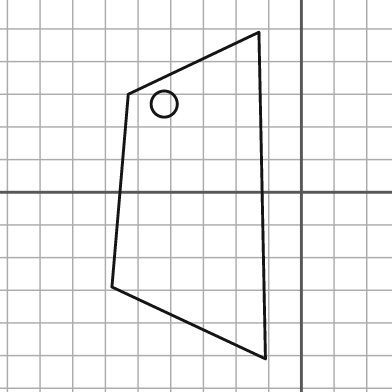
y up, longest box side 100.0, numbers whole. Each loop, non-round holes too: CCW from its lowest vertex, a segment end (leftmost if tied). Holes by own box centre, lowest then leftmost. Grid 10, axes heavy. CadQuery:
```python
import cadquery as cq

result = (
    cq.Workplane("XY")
    .moveTo(-11.0, -51.0)
    .lineTo(-13.0, 49.0)
    .lineTo(-53.0, 30.0)
    .lineTo(-58.0, -29.0)
    .close()
    .moveTo(-42.0, 27.0)
    .circle(4.0)
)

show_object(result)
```